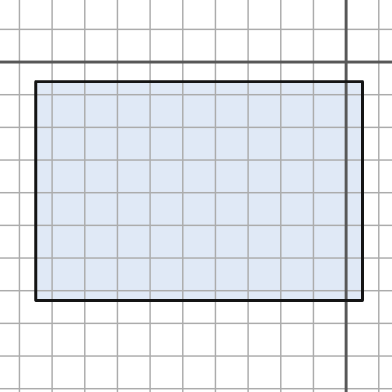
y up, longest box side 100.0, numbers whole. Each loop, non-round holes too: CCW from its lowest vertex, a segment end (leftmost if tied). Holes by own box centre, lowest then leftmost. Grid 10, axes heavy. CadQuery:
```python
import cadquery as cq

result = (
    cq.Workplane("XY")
    .moveTo(-95.0, -73.0)
    .lineTo(5.0, -73.0)
    .lineTo(5.0, -6.0)
    .lineTo(-95.0, -6.0)
    .close()
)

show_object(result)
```